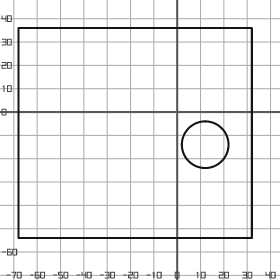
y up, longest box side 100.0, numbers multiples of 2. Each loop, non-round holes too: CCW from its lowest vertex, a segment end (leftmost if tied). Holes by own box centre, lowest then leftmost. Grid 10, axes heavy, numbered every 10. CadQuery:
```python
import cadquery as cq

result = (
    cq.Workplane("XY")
    .moveTo(-68.0, -54.0)
    .lineTo(32.0, -54.0)
    .lineTo(32.0, 36.0)
    .lineTo(-68.0, 36.0)
    .close()
    .moveTo(12.0, -14.0)
    .circle(10.0)
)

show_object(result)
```